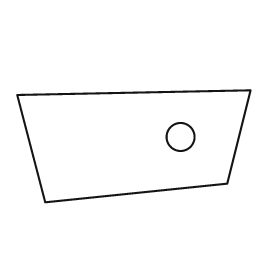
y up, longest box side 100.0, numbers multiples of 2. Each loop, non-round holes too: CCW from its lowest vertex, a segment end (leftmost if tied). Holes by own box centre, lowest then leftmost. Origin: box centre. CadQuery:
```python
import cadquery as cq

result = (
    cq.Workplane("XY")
    .moveTo(-38.0, -24.0)
    .lineTo(40.0, -16.0)
    .lineTo(50.0, 24.0)
    .lineTo(-50.0, 22.0)
    .close()
    .moveTo(20.0, 4.0)
    .circle(6.0)
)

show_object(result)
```